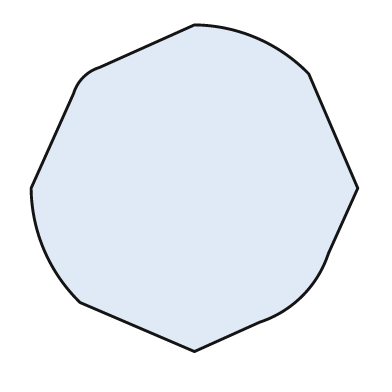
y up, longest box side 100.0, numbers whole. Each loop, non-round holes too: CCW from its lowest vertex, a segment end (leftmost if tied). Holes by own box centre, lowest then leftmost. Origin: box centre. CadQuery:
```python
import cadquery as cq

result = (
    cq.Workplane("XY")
    .moveTo(0.0, -50.0)
    .lineTo(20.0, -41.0)
    .threePointArc((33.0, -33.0), (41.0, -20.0))
    .lineTo(50.0, 0.0)
    .lineTo(35.0, 35.0)
    .threePointArc((19.0, 46.0), (0.0, 50.0))
    .lineTo(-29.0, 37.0)
    .threePointArc((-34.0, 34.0), (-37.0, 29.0))
    .lineTo(-50.0, 0.0)
    .threePointArc((-46.0, -19.0), (-35.0, -35.0))
    .close()
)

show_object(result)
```